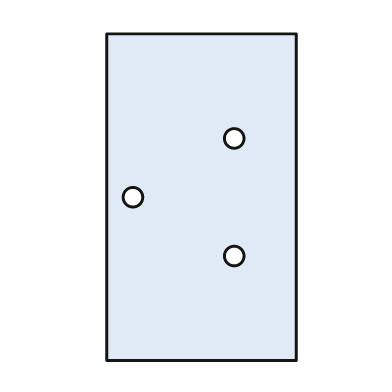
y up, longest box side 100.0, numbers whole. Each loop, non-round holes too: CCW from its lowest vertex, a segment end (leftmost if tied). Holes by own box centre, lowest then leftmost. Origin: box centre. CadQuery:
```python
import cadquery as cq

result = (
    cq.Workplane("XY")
    .moveTo(-29.0, -50.0)
    .lineTo(29.0, -50.0)
    .lineTo(29.0, 50.0)
    .lineTo(-29.0, 50.0)
    .close()
    .moveTo(10.0, -18.0)
    .circle(3.0)
    .moveTo(-21.0, 0.0)
    .circle(3.0)
    .moveTo(10.0, 18.0)
    .circle(3.0)
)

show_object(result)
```